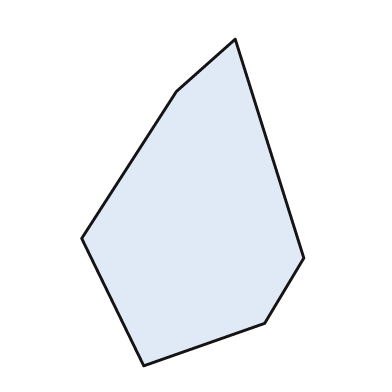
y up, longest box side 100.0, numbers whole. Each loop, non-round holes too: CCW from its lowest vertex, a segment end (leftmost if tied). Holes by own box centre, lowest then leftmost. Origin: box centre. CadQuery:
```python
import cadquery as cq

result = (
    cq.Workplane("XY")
    .moveTo(-15.0, -50.0)
    .lineTo(22.0, -37.0)
    .lineTo(34.0, -17.0)
    .lineTo(13.0, 50.0)
    .lineTo(-5.0, 34.0)
    .lineTo(-34.0, -11.0)
    .close()
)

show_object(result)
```